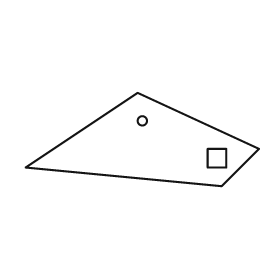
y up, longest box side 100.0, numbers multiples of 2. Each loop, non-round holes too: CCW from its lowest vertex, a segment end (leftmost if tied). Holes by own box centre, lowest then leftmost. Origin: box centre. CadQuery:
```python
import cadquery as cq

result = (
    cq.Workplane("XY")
    .moveTo(34.0, -20.0)
    .lineTo(50.0, -4.0)
    .lineTo(-2.0, 20.0)
    .lineTo(-50.0, -12.0)
    .close()
    .moveTo(28.0, -12.0)
    .lineTo(36.0, -12.0)
    .lineTo(36.0, -4.0)
    .lineTo(28.0, -4.0)
    .close()
    .moveTo(0.0, 8.0)
    .circle(2.0)
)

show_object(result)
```